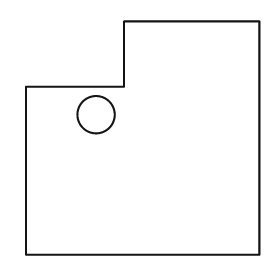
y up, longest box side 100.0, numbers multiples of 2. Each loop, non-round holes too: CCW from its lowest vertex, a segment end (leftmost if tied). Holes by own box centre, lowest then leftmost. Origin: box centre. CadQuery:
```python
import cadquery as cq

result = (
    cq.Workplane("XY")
    .moveTo(-50.0, -50.0)
    .lineTo(50.0, -50.0)
    .lineTo(50.0, 50.0)
    .lineTo(-8.0, 50.0)
    .lineTo(-8.0, 22.0)
    .lineTo(-50.0, 22.0)
    .close()
    .moveTo(-20.0, 10.0)
    .circle(8.0)
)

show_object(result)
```